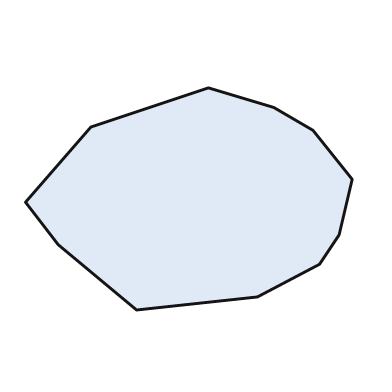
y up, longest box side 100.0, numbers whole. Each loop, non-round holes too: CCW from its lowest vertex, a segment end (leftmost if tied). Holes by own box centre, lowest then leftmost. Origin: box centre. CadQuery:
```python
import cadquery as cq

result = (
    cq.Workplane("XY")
    .moveTo(-16.0, -34.0)
    .lineTo(21.0, -30.0)
    .lineTo(40.0, -20.0)
    .lineTo(46.0, -11.0)
    .lineTo(50.0, 6.0)
    .lineTo(38.0, 21.0)
    .lineTo(26.0, 28.0)
    .lineTo(6.0, 34.0)
    .lineTo(-30.0, 22.0)
    .lineTo(-50.0, -1.0)
    .lineTo(-40.0, -14.0)
    .close()
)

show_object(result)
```